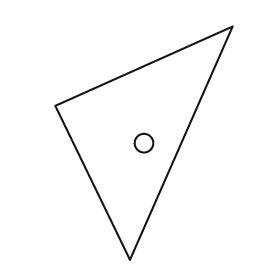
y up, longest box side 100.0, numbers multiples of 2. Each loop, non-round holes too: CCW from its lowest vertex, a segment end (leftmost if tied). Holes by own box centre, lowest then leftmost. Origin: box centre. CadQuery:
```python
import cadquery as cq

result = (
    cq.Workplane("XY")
    .moveTo(-6.0, -50.0)
    .lineTo(38.0, 50.0)
    .lineTo(-38.0, 16.0)
    .close()
    .moveTo(0.0, 0.0)
    .circle(4.0)
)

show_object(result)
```